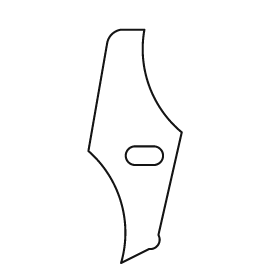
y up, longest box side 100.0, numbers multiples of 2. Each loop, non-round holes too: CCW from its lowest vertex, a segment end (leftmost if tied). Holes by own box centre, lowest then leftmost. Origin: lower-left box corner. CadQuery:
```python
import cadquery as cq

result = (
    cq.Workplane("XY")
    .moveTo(14.0, 0.0)
    .lineTo(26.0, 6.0)
    .threePointArc((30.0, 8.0), (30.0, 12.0))
    .lineTo(40.0, 56.0)
    .threePointArc((26.0, 76.0), (24.0, 100.0))
    .lineTo(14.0, 100.0)
    .threePointArc((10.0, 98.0), (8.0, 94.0))
    .lineTo(0.0, 48.0)
    .threePointArc((14.0, 26.0), (14.0, 0.0))
    .close()
    .moveTo(20.0, 42.0)
    .lineTo(28.0, 42.0)
    .threePointArc((32.0, 46.0), (28.0, 50.0))
    .lineTo(20.0, 50.0)
    .threePointArc((16.0, 46.0), (20.0, 42.0))
    .close()
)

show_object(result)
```